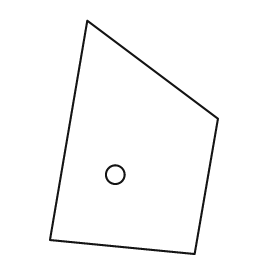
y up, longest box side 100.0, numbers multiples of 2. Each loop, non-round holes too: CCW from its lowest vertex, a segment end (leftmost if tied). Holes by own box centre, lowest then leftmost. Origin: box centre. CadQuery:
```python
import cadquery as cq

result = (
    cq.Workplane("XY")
    .moveTo(26.0, -50.0)
    .lineTo(36.0, 8.0)
    .lineTo(-20.0, 50.0)
    .lineTo(-36.0, -44.0)
    .close()
    .moveTo(-8.0, -16.0)
    .circle(4.0)
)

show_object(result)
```